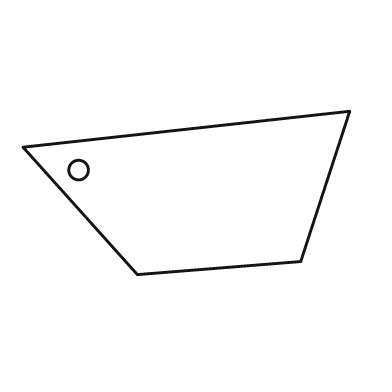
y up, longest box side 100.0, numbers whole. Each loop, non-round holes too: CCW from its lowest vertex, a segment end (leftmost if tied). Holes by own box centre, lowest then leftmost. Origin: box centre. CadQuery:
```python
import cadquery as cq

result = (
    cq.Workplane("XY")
    .moveTo(-15.0, -25.0)
    .lineTo(35.0, -21.0)
    .lineTo(50.0, 25.0)
    .lineTo(-50.0, 14.0)
    .close()
    .moveTo(-33.0, 7.0)
    .circle(3.0)
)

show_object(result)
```